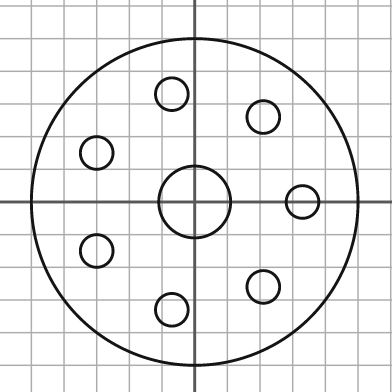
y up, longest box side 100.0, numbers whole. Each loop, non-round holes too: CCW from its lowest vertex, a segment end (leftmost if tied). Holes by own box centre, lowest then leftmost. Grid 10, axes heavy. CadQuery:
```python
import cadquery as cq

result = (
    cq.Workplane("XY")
    .moveTo(0.0, 0.0)
    .circle(50.0)
    .moveTo(-7.0, -33.0)
    .circle(5.0)
    .moveTo(21.0, -26.0)
    .circle(5.0)
    .moveTo(-30.0, -15.0)
    .circle(5.0)
    .moveTo(0.0, 0.0)
    .circle(11.0)
    .moveTo(33.0, 0.0)
    .circle(5.0)
    .moveTo(-30.0, 15.0)
    .circle(5.0)
    .moveTo(21.0, 26.0)
    .circle(5.0)
    .moveTo(-7.0, 33.0)
    .circle(5.0)
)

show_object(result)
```